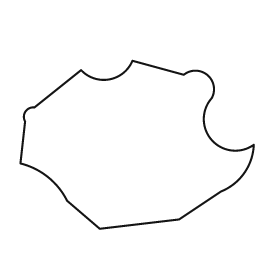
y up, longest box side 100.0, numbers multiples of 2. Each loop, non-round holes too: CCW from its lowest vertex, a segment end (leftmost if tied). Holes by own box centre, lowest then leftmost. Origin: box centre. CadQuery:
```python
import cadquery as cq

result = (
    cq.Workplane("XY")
    .moveTo(-16.0, -36.0)
    .lineTo(18.0, -32.0)
    .lineTo(36.0, -20.0)
    .threePointArc((46.0, -12.0), (50.0, 0.0))
    .threePointArc((32.0, 2.0), (32.0, 20.0))
    .threePointArc((30.0, 30.0), (20.0, 30.0))
    .lineTo(-2.0, 36.0)
    .threePointArc((-12.0, 28.0), (-24.0, 32.0))
    .lineTo(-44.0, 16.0)
    .threePointArc((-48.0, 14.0), (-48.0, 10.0))
    .lineTo(-50.0, -8.0)
    .threePointArc((-38.0, -14.0), (-30.0, -24.0))
    .close()
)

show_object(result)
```